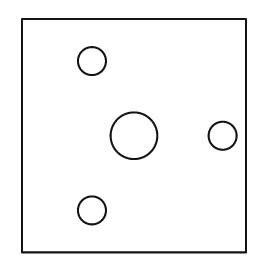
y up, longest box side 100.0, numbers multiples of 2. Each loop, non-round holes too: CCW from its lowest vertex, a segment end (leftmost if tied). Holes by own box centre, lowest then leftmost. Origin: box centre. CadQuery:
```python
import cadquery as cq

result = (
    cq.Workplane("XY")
    .moveTo(-48.0, -50.0)
    .lineTo(48.0, -50.0)
    .lineTo(48.0, 50.0)
    .lineTo(-48.0, 50.0)
    .close()
    .moveTo(-18.0, -32.0)
    .circle(6.0)
    .moveTo(0.0, 0.0)
    .circle(10.0)
    .moveTo(38.0, 0.0)
    .circle(6.0)
    .moveTo(-18.0, 32.0)
    .circle(6.0)
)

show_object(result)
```